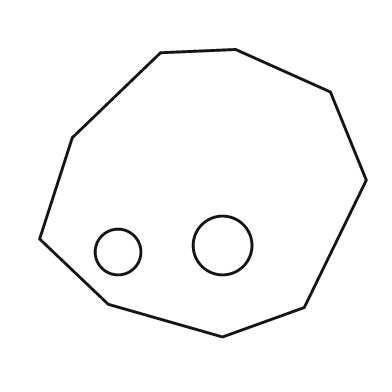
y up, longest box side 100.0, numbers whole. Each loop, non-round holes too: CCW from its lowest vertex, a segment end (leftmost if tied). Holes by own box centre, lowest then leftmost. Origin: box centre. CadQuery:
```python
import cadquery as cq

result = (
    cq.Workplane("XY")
    .moveTo(6.0, -44.0)
    .lineTo(31.0, -35.0)
    .lineTo(50.0, 4.0)
    .lineTo(39.0, 31.0)
    .lineTo(10.0, 44.0)
    .lineTo(-13.0, 43.0)
    .lineTo(-40.0, 17.0)
    .lineTo(-50.0, -14.0)
    .lineTo(-29.0, -34.0)
    .close()
    .moveTo(-26.0, -18.0)
    .circle(7.0)
    .moveTo(6.0, -16.0)
    .circle(9.0)
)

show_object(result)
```